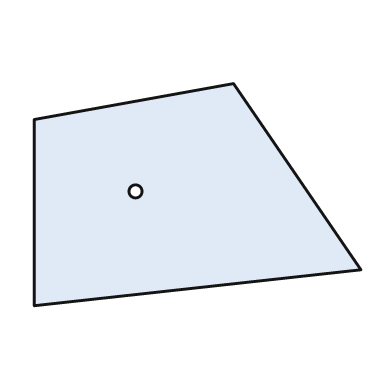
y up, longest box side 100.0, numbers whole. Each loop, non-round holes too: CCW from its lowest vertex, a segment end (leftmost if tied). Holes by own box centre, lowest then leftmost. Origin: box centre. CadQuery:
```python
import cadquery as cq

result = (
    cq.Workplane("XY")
    .moveTo(-50.0, -34.0)
    .lineTo(50.0, -23.0)
    .lineTo(11.0, 34.0)
    .lineTo(-50.0, 23.0)
    .close()
    .moveTo(-19.0, 1.0)
    .circle(2.0)
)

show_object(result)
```